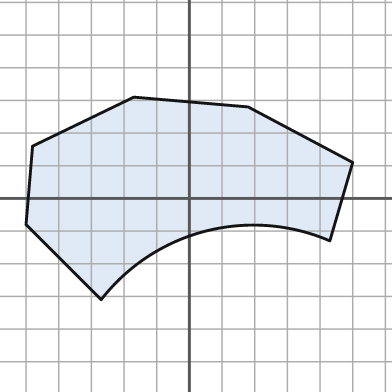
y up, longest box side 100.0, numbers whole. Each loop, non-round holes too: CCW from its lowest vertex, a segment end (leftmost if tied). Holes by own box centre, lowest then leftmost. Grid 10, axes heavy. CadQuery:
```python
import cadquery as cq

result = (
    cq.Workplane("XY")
    .moveTo(-27.0, -31.0)
    .threePointArc((5.0, -10.0), (43.0, -13.0))
    .lineTo(50.0, 11.0)
    .lineTo(18.0, 28.0)
    .lineTo(-17.0, 31.0)
    .lineTo(-48.0, 16.0)
    .lineTo(-50.0, -8.0)
    .close()
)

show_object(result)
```